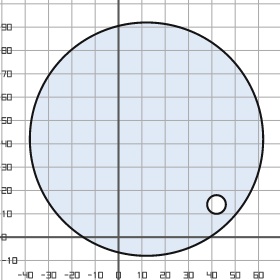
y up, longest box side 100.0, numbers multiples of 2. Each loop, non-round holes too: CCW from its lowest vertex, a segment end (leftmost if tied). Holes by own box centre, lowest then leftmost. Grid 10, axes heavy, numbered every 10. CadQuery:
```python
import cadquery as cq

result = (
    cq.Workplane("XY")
    .moveTo(12.0, 42.0)
    .circle(50.0)
    .moveTo(42.0, 14.0)
    .circle(4.0)
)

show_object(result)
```